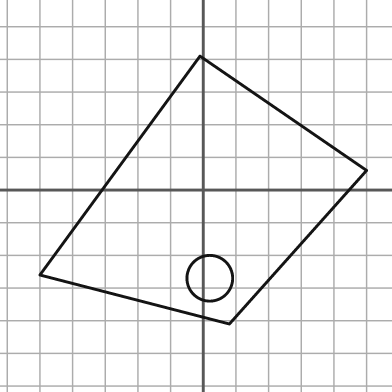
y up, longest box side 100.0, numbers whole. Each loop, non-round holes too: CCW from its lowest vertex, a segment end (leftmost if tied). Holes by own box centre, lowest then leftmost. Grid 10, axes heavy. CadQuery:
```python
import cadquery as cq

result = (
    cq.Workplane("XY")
    .moveTo(8.0, -41.0)
    .lineTo(50.0, 6.0)
    .lineTo(-1.0, 41.0)
    .lineTo(-50.0, -26.0)
    .close()
    .moveTo(2.0, -27.0)
    .circle(7.0)
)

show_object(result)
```